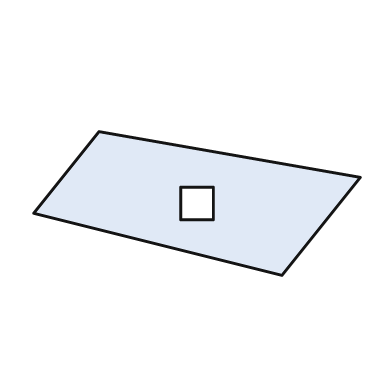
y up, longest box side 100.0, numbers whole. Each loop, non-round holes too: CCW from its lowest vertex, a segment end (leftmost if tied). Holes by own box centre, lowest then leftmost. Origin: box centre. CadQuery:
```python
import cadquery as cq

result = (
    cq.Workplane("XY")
    .moveTo(26.0, -22.0)
    .lineTo(50.0, 8.0)
    .lineTo(-30.0, 22.0)
    .lineTo(-50.0, -3.0)
    .close()
    .moveTo(-5.0, -5.0)
    .lineTo(5.0, -5.0)
    .lineTo(5.0, 5.0)
    .lineTo(-5.0, 5.0)
    .close()
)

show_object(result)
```